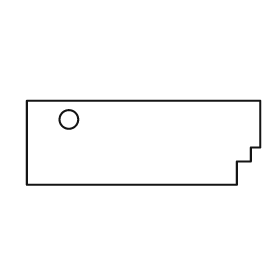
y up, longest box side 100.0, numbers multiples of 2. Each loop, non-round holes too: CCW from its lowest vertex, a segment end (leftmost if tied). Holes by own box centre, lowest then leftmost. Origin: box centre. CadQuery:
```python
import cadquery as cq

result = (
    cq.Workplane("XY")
    .moveTo(-50.0, -18.0)
    .lineTo(40.0, -18.0)
    .lineTo(40.0, -8.0)
    .lineTo(46.0, -8.0)
    .lineTo(46.0, -2.0)
    .lineTo(50.0, -2.0)
    .lineTo(50.0, 18.0)
    .lineTo(-50.0, 18.0)
    .close()
    .moveTo(-32.0, 10.0)
    .circle(4.0)
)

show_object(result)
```